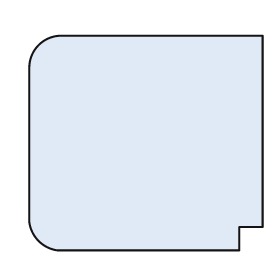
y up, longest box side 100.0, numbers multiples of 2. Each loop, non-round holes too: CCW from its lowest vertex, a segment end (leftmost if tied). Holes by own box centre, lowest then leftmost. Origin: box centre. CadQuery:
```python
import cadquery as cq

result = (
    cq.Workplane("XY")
    .moveTo(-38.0, -46.0)
    .lineTo(40.0, -46.0)
    .lineTo(40.0, -36.0)
    .lineTo(50.0, -36.0)
    .lineTo(50.0, 46.0)
    .lineTo(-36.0, 46.0)
    .threePointArc((-46.0, 42.0), (-50.0, 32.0))
    .lineTo(-50.0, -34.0)
    .threePointArc((-46.0, -42.0), (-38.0, -46.0))
    .close()
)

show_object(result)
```